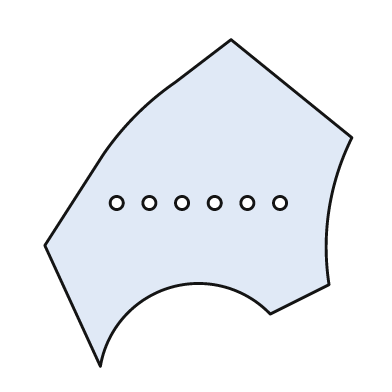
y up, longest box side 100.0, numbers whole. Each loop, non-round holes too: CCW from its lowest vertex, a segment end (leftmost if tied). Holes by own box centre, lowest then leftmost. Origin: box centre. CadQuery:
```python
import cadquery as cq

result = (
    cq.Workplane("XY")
    .moveTo(-30.0, -50.0)
    .threePointArc((-9.0, -26.0), (22.0, -34.0))
    .lineTo(40.0, -25.0)
    .threePointArc((40.0, -2.0), (47.0, 20.0))
    .lineTo(10.0, 50.0)
    .lineTo(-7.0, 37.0)
    .threePointArc((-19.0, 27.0), (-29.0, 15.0))
    .lineTo(-47.0, -13.0)
    .close()
    .moveTo(-25.0, 0.0)
    .circle(2.0)
    .moveTo(-15.0, 0.0)
    .circle(2.0)
    .moveTo(-5.0, 0.0)
    .circle(2.0)
    .moveTo(5.0, 0.0)
    .circle(2.0)
    .moveTo(15.0, 0.0)
    .circle(2.0)
    .moveTo(25.0, 0.0)
    .circle(2.0)
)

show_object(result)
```